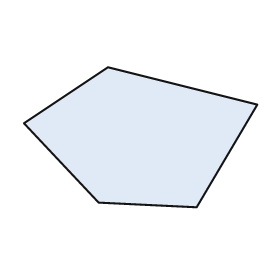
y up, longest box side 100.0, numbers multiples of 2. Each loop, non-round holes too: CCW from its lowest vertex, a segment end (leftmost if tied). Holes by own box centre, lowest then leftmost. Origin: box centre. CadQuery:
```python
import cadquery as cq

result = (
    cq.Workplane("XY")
    .moveTo(24.0, -30.0)
    .lineTo(50.0, 14.0)
    .lineTo(-14.0, 30.0)
    .lineTo(-50.0, 6.0)
    .lineTo(-18.0, -28.0)
    .close()
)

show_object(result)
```